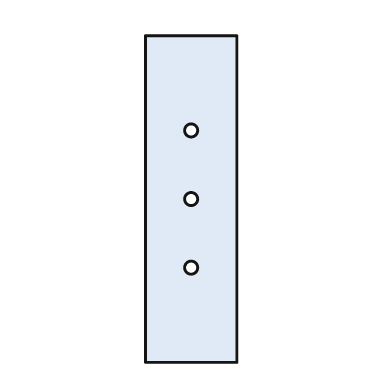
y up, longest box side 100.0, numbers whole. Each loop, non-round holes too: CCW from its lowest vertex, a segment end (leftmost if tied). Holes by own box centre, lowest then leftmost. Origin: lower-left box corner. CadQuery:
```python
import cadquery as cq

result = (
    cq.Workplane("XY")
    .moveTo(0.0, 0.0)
    .lineTo(28.0, 0.0)
    .lineTo(28.0, 100.0)
    .lineTo(0.0, 100.0)
    .close()
    .moveTo(14.0, 29.0)
    .circle(2.0)
    .moveTo(14.0, 50.0)
    .circle(2.0)
    .moveTo(14.0, 71.0)
    .circle(2.0)
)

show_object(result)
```